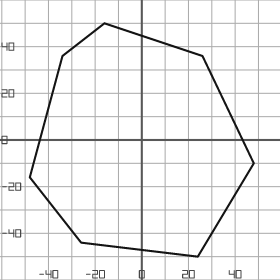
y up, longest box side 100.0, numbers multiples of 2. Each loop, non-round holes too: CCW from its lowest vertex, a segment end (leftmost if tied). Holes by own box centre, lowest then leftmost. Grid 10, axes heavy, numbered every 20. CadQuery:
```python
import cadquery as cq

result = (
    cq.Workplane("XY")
    .moveTo(24.0, -50.0)
    .lineTo(48.0, -10.0)
    .lineTo(26.0, 36.0)
    .lineTo(-16.0, 50.0)
    .lineTo(-34.0, 36.0)
    .lineTo(-48.0, -16.0)
    .lineTo(-26.0, -44.0)
    .close()
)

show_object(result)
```